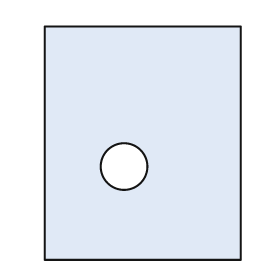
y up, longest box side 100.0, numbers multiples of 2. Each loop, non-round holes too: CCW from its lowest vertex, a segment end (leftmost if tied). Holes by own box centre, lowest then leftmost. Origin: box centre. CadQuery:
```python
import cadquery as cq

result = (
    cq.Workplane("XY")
    .moveTo(-42.0, -50.0)
    .lineTo(42.0, -50.0)
    .lineTo(42.0, 50.0)
    .lineTo(-42.0, 50.0)
    .close()
    .moveTo(-8.0, -10.0)
    .circle(10.0)
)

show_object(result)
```